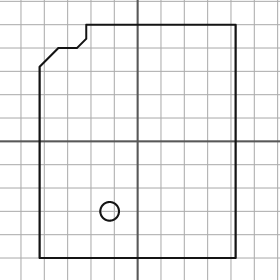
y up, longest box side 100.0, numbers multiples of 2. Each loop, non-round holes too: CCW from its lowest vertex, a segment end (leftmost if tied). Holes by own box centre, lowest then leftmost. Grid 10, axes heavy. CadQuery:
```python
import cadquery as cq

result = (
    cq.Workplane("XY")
    .moveTo(-42.0, -50.0)
    .lineTo(42.0, -50.0)
    .lineTo(42.0, 50.0)
    .lineTo(-22.0, 50.0)
    .lineTo(-22.0, 44.0)
    .lineTo(-26.0, 40.0)
    .lineTo(-34.0, 40.0)
    .lineTo(-42.0, 32.0)
    .close()
    .moveTo(-12.0, -30.0)
    .circle(4.0)
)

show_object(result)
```